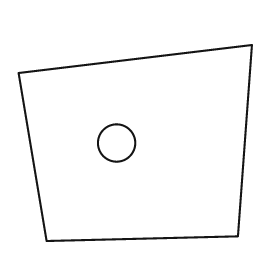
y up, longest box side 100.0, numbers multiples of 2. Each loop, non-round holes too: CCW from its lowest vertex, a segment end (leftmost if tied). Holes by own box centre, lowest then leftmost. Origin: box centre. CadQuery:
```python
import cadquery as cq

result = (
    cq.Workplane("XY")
    .moveTo(-38.0, -42.0)
    .lineTo(44.0, -40.0)
    .lineTo(50.0, 42.0)
    .lineTo(-50.0, 30.0)
    .close()
    .moveTo(-8.0, 0.0)
    .circle(8.0)
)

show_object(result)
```